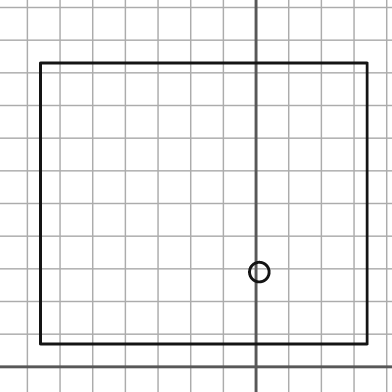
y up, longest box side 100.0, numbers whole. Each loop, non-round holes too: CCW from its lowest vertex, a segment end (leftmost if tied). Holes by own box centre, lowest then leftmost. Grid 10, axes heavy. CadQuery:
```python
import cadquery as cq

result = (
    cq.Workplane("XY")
    .moveTo(-66.0, 7.0)
    .lineTo(34.0, 7.0)
    .lineTo(34.0, 93.0)
    .lineTo(-66.0, 93.0)
    .close()
    .moveTo(1.0, 29.0)
    .circle(3.0)
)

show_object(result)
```